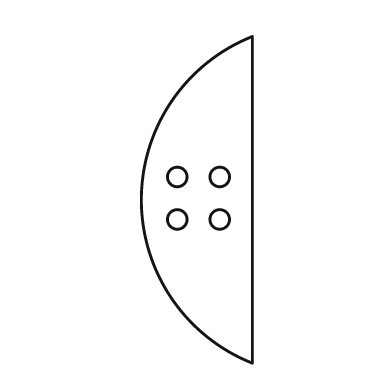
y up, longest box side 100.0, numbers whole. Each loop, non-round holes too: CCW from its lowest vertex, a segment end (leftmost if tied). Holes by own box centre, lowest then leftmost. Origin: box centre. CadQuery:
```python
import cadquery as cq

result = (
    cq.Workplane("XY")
    .moveTo(17.0, -50.0)
    .lineTo(17.0, 50.0)
    .threePointArc((-17.0, 0.0), (17.0, -50.0))
    .close()
    .moveTo(-6.0, -6.0)
    .circle(3.0)
    .moveTo(7.0, -6.0)
    .circle(3.0)
    .moveTo(-6.0, 7.0)
    .circle(3.0)
    .moveTo(7.0, 7.0)
    .circle(3.0)
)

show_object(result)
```